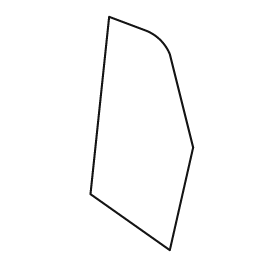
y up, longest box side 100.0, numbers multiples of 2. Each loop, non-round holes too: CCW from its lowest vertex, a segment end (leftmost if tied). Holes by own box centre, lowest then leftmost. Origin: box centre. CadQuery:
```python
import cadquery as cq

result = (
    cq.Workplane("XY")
    .moveTo(12.0, -50.0)
    .lineTo(22.0, -6.0)
    .lineTo(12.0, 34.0)
    .threePointArc((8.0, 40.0), (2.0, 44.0))
    .lineTo(-14.0, 50.0)
    .lineTo(-22.0, -26.0)
    .close()
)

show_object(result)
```